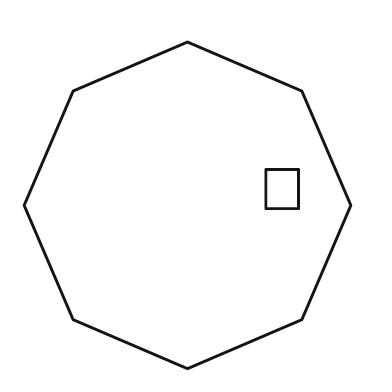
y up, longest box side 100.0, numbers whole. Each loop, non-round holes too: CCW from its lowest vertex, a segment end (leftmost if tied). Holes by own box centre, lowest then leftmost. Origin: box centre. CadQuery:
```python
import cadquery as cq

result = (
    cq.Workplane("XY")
    .moveTo(0.0, -50.0)
    .lineTo(35.0, -35.0)
    .lineTo(50.0, 0.0)
    .lineTo(35.0, 35.0)
    .lineTo(0.0, 50.0)
    .lineTo(-35.0, 35.0)
    .lineTo(-50.0, 0.0)
    .lineTo(-35.0, -35.0)
    .close()
    .moveTo(24.0, -1.0)
    .lineTo(34.0, -1.0)
    .lineTo(34.0, 11.0)
    .lineTo(24.0, 11.0)
    .close()
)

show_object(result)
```